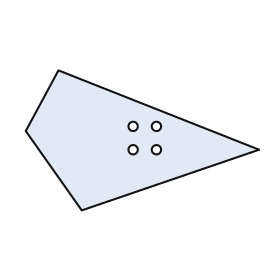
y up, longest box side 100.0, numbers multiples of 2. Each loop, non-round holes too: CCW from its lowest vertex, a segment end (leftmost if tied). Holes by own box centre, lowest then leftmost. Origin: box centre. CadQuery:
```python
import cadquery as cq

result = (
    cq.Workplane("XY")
    .moveTo(-26.0, -30.0)
    .lineTo(50.0, -4.0)
    .lineTo(-36.0, 30.0)
    .lineTo(-50.0, 4.0)
    .close()
    .moveTo(-4.0, -4.0)
    .circle(2.0)
    .moveTo(6.0, -4.0)
    .circle(2.0)
    .moveTo(-4.0, 6.0)
    .circle(2.0)
    .moveTo(6.0, 6.0)
    .circle(2.0)
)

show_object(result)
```